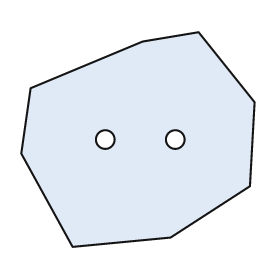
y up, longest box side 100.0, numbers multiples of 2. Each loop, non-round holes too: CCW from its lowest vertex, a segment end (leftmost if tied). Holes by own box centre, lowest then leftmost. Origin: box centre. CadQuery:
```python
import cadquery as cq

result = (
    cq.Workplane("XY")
    .moveTo(-28.0, -46.0)
    .lineTo(14.0, -42.0)
    .lineTo(48.0, -20.0)
    .lineTo(50.0, 16.0)
    .lineTo(26.0, 46.0)
    .lineTo(2.0, 42.0)
    .lineTo(-46.0, 22.0)
    .lineTo(-50.0, -6.0)
    .close()
    .moveTo(-14.0, 0.0)
    .circle(4.0)
    .moveTo(16.0, 0.0)
    .circle(4.0)
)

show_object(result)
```